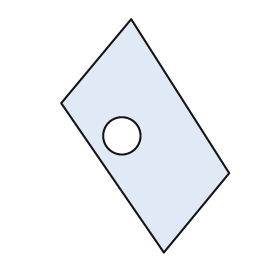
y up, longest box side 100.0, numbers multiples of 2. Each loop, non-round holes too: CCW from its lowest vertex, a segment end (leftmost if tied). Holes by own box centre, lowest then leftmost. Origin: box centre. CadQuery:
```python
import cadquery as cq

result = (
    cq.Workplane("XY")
    .moveTo(8.0, -50.0)
    .lineTo(36.0, -16.0)
    .lineTo(-6.0, 50.0)
    .lineTo(-36.0, 14.0)
    .close()
    .moveTo(-10.0, 0.0)
    .circle(8.0)
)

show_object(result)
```